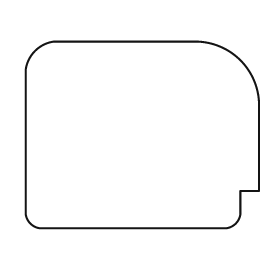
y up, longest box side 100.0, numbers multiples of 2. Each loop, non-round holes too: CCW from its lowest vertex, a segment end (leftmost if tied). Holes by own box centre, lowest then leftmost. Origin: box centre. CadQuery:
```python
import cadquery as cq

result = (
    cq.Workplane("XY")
    .moveTo(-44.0, -40.0)
    .lineTo(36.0, -40.0)
    .threePointArc((40.0, -38.0), (42.0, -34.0))
    .lineTo(42.0, -24.0)
    .lineTo(50.0, -24.0)
    .lineTo(50.0, 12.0)
    .threePointArc((42.0, 32.0), (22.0, 40.0))
    .lineTo(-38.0, 40.0)
    .threePointArc((-46.0, 36.0), (-50.0, 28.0))
    .lineTo(-50.0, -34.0)
    .threePointArc((-48.0, -38.0), (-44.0, -40.0))
    .close()
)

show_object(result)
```